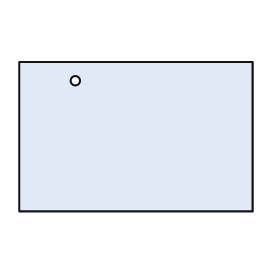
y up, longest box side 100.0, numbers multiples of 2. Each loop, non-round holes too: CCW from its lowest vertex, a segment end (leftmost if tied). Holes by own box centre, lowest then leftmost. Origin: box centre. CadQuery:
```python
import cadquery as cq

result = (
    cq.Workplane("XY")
    .moveTo(-50.0, -32.0)
    .lineTo(50.0, -32.0)
    .lineTo(50.0, 32.0)
    .lineTo(-50.0, 32.0)
    .close()
    .moveTo(-26.0, 24.0)
    .circle(2.0)
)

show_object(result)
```